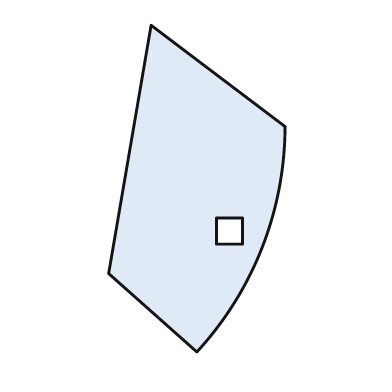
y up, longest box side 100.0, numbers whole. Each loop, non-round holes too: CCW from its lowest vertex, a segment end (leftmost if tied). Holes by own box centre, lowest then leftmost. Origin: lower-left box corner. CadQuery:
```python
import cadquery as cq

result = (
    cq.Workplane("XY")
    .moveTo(27.0, 0.0)
    .threePointArc((47.0, 32.0), (54.0, 69.0))
    .lineTo(13.0, 100.0)
    .lineTo(0.0, 24.0)
    .close()
    .moveTo(33.0, 33.0)
    .lineTo(41.0, 33.0)
    .lineTo(41.0, 41.0)
    .lineTo(33.0, 41.0)
    .close()
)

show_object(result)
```